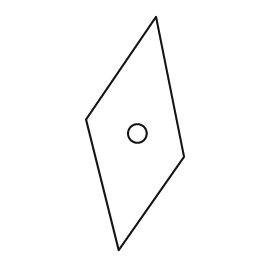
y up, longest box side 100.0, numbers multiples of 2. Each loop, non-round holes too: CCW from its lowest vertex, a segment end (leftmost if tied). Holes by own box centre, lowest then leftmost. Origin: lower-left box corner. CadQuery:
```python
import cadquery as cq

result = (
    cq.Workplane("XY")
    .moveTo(14.0, 0.0)
    .lineTo(42.0, 40.0)
    .lineTo(30.0, 100.0)
    .lineTo(0.0, 56.0)
    .close()
    .moveTo(22.0, 50.0)
    .circle(4.0)
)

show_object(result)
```